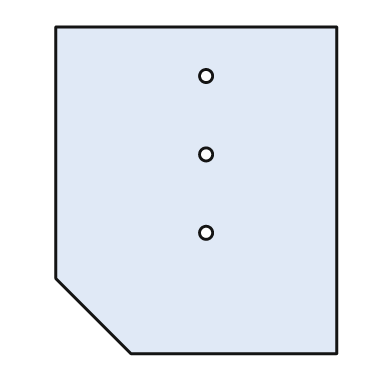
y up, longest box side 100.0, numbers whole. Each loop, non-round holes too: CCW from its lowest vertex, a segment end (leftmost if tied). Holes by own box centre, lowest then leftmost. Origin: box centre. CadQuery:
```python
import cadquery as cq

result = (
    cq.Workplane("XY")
    .moveTo(-20.0, -50.0)
    .lineTo(43.0, -50.0)
    .lineTo(43.0, 50.0)
    .lineTo(-43.0, 50.0)
    .lineTo(-43.0, -27.0)
    .close()
    .moveTo(3.0, -13.0)
    .circle(2.0)
    .moveTo(3.0, 11.0)
    .circle(2.0)
    .moveTo(3.0, 35.0)
    .circle(2.0)
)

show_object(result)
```